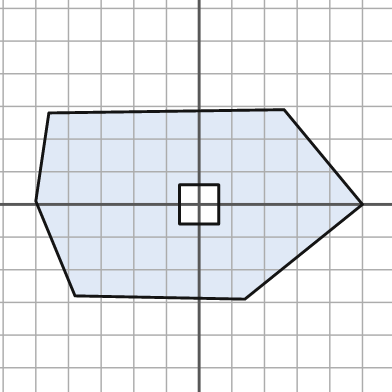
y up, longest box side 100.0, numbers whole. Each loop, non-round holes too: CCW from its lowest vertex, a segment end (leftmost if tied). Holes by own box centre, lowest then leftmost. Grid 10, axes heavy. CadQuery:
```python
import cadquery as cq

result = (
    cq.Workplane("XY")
    .moveTo(14.0, -29.0)
    .lineTo(50.0, 0.0)
    .lineTo(26.0, 29.0)
    .lineTo(-46.0, 28.0)
    .lineTo(-50.0, 1.0)
    .lineTo(-38.0, -28.0)
    .close()
    .moveTo(-6.0, -6.0)
    .lineTo(6.0, -6.0)
    .lineTo(6.0, 6.0)
    .lineTo(-6.0, 6.0)
    .close()
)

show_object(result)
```